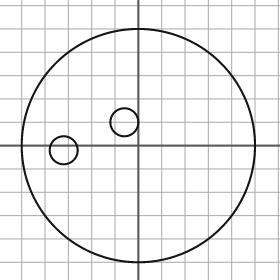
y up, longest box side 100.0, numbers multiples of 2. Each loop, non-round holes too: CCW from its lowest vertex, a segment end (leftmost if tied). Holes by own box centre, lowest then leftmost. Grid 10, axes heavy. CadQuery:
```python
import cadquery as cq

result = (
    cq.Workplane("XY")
    .moveTo(0.0, 0.0)
    .circle(50.0)
    .moveTo(-32.0, -2.0)
    .circle(6.0)
    .moveTo(-6.0, 10.0)
    .circle(6.0)
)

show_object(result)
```